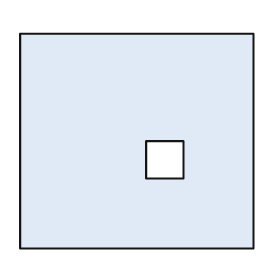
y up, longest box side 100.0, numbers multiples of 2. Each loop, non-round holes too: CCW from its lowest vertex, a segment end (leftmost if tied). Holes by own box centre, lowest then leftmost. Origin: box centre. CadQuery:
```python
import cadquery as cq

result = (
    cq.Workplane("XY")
    .moveTo(-50.0, -46.0)
    .lineTo(50.0, -46.0)
    .lineTo(50.0, 46.0)
    .lineTo(-50.0, 46.0)
    .close()
    .moveTo(4.0, -16.0)
    .lineTo(20.0, -16.0)
    .lineTo(20.0, 0.0)
    .lineTo(4.0, 0.0)
    .close()
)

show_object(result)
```